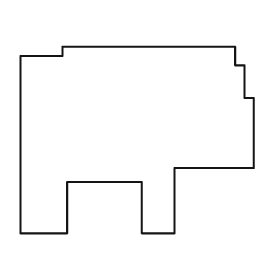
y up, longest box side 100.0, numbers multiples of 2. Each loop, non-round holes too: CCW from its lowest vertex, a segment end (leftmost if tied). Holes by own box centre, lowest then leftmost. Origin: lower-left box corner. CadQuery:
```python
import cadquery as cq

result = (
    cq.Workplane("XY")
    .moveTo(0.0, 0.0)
    .lineTo(20.0, 0.0)
    .lineTo(20.0, 22.0)
    .lineTo(52.0, 22.0)
    .lineTo(52.0, 0.0)
    .lineTo(66.0, 0.0)
    .lineTo(66.0, 28.0)
    .lineTo(100.0, 28.0)
    .lineTo(100.0, 58.0)
    .lineTo(96.0, 58.0)
    .lineTo(96.0, 72.0)
    .lineTo(92.0, 72.0)
    .lineTo(92.0, 80.0)
    .lineTo(18.0, 80.0)
    .lineTo(18.0, 76.0)
    .lineTo(0.0, 76.0)
    .close()
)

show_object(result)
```